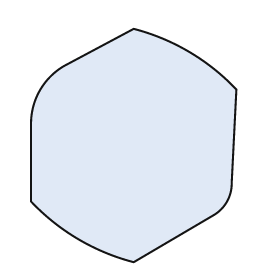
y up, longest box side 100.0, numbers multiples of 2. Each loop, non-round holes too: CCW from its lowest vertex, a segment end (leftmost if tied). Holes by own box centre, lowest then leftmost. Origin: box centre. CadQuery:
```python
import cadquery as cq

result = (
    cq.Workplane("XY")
    .moveTo(0.0, -50.0)
    .lineTo(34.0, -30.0)
    .threePointArc((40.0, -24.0), (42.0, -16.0))
    .lineTo(44.0, 24.0)
    .threePointArc((24.0, 40.0), (0.0, 50.0))
    .lineTo(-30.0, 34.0)
    .threePointArc((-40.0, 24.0), (-44.0, 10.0))
    .lineTo(-44.0, -24.0)
    .threePointArc((-24.0, -40.0), (0.0, -50.0))
    .close()
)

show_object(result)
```